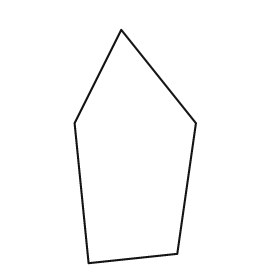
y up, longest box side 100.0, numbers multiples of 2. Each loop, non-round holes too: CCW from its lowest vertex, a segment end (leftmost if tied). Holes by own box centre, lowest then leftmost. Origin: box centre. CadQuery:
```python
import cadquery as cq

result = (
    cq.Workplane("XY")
    .moveTo(-20.0, -50.0)
    .lineTo(18.0, -46.0)
    .lineTo(26.0, 10.0)
    .lineTo(-6.0, 50.0)
    .lineTo(-26.0, 10.0)
    .close()
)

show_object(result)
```